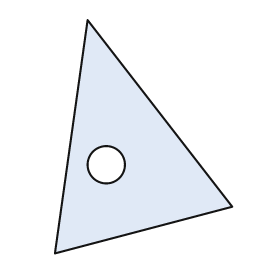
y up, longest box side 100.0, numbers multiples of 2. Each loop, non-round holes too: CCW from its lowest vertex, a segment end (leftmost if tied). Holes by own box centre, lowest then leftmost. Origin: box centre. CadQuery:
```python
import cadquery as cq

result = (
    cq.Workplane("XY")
    .moveTo(-38.0, -50.0)
    .lineTo(38.0, -30.0)
    .lineTo(-24.0, 50.0)
    .close()
    .moveTo(-16.0, -12.0)
    .circle(8.0)
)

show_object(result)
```